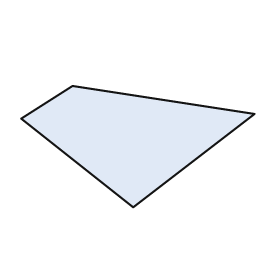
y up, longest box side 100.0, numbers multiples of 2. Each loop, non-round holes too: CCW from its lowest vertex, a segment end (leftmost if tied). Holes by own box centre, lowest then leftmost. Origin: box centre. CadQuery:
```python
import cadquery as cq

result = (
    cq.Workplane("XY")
    .moveTo(-2.0, -26.0)
    .lineTo(50.0, 14.0)
    .lineTo(-28.0, 26.0)
    .lineTo(-50.0, 12.0)
    .close()
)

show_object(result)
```